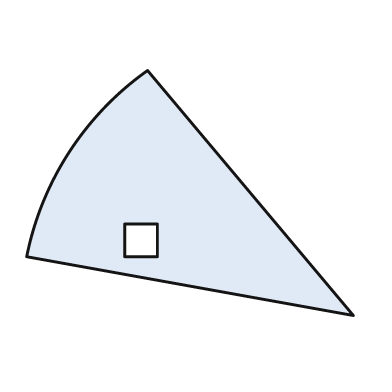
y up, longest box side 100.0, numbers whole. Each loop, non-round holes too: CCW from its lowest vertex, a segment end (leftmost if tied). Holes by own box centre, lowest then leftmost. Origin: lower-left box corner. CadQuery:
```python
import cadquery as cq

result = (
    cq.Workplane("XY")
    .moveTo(100.0, 0.0)
    .lineTo(37.0, 75.0)
    .threePointArc((13.0, 50.0), (0.0, 18.0))
    .close()
    .moveTo(30.0, 18.0)
    .lineTo(40.0, 18.0)
    .lineTo(40.0, 28.0)
    .lineTo(30.0, 28.0)
    .close()
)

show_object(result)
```